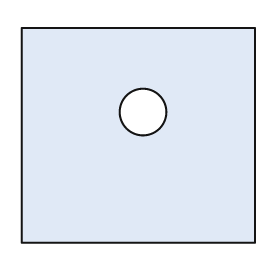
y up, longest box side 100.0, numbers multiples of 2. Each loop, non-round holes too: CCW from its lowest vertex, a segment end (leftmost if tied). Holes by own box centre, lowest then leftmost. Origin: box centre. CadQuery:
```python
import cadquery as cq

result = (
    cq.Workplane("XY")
    .moveTo(-50.0, -46.0)
    .lineTo(50.0, -46.0)
    .lineTo(50.0, 46.0)
    .lineTo(-50.0, 46.0)
    .close()
    .moveTo(2.0, 10.0)
    .circle(10.0)
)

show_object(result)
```